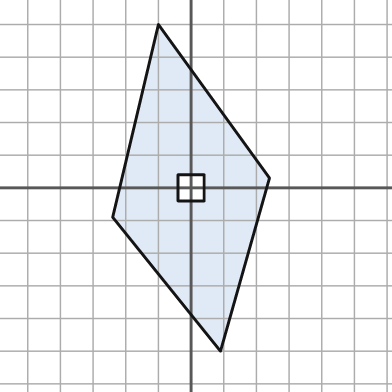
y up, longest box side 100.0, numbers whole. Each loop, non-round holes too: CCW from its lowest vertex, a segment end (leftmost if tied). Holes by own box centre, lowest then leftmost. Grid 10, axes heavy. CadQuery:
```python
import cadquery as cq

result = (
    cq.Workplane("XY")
    .moveTo(9.0, -50.0)
    .lineTo(24.0, 3.0)
    .lineTo(-10.0, 50.0)
    .lineTo(-24.0, -9.0)
    .close()
    .moveTo(-4.0, -4.0)
    .lineTo(4.0, -4.0)
    .lineTo(4.0, 4.0)
    .lineTo(-4.0, 4.0)
    .close()
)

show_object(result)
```